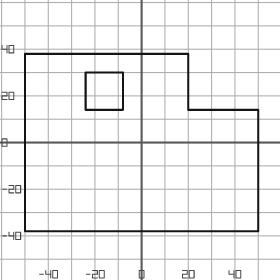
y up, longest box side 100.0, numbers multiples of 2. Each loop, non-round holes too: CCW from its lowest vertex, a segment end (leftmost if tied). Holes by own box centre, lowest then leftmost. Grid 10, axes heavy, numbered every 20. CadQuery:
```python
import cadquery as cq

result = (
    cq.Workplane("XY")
    .moveTo(-50.0, -38.0)
    .lineTo(50.0, -38.0)
    .lineTo(50.0, 14.0)
    .lineTo(20.0, 14.0)
    .lineTo(20.0, 38.0)
    .lineTo(-50.0, 38.0)
    .close()
    .moveTo(-24.0, 14.0)
    .lineTo(-8.0, 14.0)
    .lineTo(-8.0, 30.0)
    .lineTo(-24.0, 30.0)
    .close()
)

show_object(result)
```